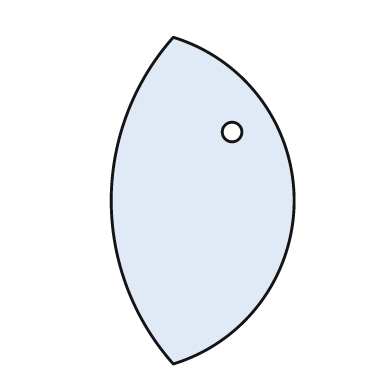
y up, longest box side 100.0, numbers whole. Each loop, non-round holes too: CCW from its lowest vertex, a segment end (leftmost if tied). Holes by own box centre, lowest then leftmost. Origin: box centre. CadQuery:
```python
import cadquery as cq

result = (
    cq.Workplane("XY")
    .moveTo(-9.0, -50.0)
    .threePointArc((28.0, 0.0), (-9.0, 50.0))
    .threePointArc((-28.0, 0.0), (-9.0, -50.0))
    .close()
    .moveTo(9.0, 21.0)
    .circle(3.0)
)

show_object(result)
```